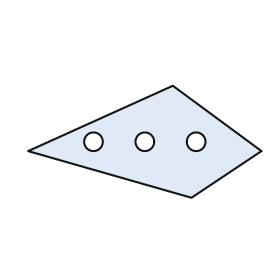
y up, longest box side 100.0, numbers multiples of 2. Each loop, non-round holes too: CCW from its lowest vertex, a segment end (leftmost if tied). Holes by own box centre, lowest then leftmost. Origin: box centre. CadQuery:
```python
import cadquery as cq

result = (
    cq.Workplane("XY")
    .moveTo(20.0, -24.0)
    .lineTo(50.0, -4.0)
    .lineTo(12.0, 24.0)
    .lineTo(-50.0, -4.0)
    .close()
    .moveTo(-22.0, 0.0)
    .circle(4.0)
    .moveTo(0.0, 0.0)
    .circle(4.0)
    .moveTo(22.0, 0.0)
    .circle(4.0)
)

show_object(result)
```